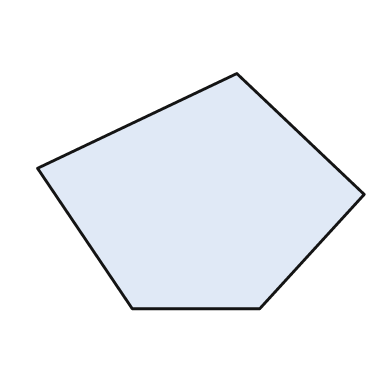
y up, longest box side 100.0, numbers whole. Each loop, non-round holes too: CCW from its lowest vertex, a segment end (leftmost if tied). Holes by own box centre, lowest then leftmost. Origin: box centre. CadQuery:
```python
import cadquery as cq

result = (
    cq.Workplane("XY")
    .moveTo(-21.0, -36.0)
    .lineTo(18.0, -36.0)
    .lineTo(50.0, -1.0)
    .lineTo(11.0, 36.0)
    .lineTo(-50.0, 7.0)
    .close()
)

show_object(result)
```